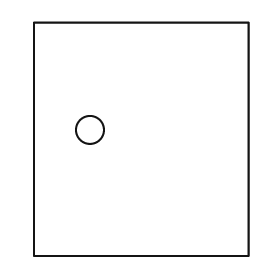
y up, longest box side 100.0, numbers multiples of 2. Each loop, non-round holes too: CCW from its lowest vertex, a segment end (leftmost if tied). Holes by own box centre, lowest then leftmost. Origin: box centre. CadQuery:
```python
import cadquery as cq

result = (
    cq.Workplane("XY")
    .moveTo(-46.0, -50.0)
    .lineTo(46.0, -50.0)
    .lineTo(46.0, 50.0)
    .lineTo(-46.0, 50.0)
    .close()
    .moveTo(-22.0, 4.0)
    .circle(6.0)
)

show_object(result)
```